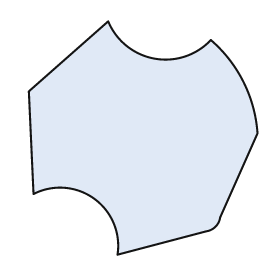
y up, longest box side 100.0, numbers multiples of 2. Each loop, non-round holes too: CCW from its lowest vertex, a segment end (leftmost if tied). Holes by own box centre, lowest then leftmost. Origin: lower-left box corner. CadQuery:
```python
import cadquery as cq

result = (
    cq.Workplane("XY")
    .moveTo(38.0, 0.0)
    .lineTo(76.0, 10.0)
    .threePointArc((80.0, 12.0), (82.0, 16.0))
    .lineTo(98.0, 52.0)
    .threePointArc((92.0, 74.0), (78.0, 92.0))
    .threePointArc((54.0, 84.0), (34.0, 100.0))
    .lineTo(0.0, 70.0)
    .lineTo(2.0, 26.0)
    .threePointArc((28.0, 24.0), (38.0, 0.0))
    .close()
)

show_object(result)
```